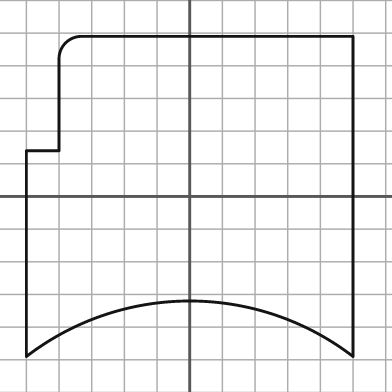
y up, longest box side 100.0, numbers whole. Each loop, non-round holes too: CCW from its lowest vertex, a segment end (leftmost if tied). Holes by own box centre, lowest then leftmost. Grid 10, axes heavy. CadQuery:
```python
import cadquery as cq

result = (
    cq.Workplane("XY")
    .moveTo(-50.0, -49.0)
    .threePointArc((0.0, -32.0), (50.0, -49.0))
    .lineTo(50.0, 49.0)
    .lineTo(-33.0, 49.0)
    .threePointArc((-38.0, 47.0), (-40.0, 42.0))
    .lineTo(-40.0, 14.0)
    .lineTo(-50.0, 14.0)
    .close()
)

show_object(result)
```